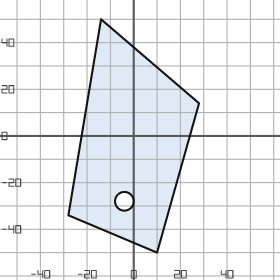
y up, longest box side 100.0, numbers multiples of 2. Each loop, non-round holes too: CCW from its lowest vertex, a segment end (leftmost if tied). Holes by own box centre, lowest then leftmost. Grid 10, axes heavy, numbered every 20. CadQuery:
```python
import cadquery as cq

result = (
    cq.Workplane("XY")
    .moveTo(10.0, -50.0)
    .lineTo(28.0, 14.0)
    .lineTo(-14.0, 50.0)
    .lineTo(-28.0, -34.0)
    .close()
    .moveTo(-4.0, -28.0)
    .circle(4.0)
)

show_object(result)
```